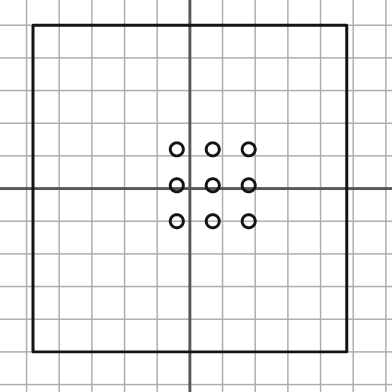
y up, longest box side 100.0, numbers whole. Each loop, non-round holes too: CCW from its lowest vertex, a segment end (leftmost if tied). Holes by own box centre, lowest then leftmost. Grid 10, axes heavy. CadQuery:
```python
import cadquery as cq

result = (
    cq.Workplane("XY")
    .moveTo(-48.0, -50.0)
    .lineTo(48.0, -50.0)
    .lineTo(48.0, 50.0)
    .lineTo(-48.0, 50.0)
    .close()
    .moveTo(-4.0, -10.0)
    .circle(2.0)
    .moveTo(7.0, -10.0)
    .circle(2.0)
    .moveTo(18.0, -10.0)
    .circle(2.0)
    .moveTo(-4.0, 1.0)
    .circle(2.0)
    .moveTo(7.0, 1.0)
    .circle(2.0)
    .moveTo(18.0, 1.0)
    .circle(2.0)
    .moveTo(-4.0, 12.0)
    .circle(2.0)
    .moveTo(7.0, 12.0)
    .circle(2.0)
    .moveTo(18.0, 12.0)
    .circle(2.0)
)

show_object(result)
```